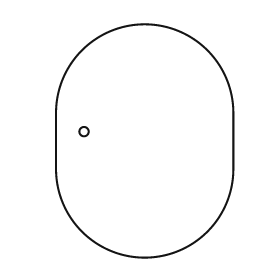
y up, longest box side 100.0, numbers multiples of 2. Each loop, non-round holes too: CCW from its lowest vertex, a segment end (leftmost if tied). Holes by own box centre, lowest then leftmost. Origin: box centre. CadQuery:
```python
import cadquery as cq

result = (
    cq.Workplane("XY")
    .moveTo(-38.0, -12.0)
    .threePointArc((0.0, -50.0), (38.0, -12.0))
    .lineTo(38.0, 12.0)
    .threePointArc((0.0, 50.0), (-38.0, 12.0))
    .close()
    .moveTo(-26.0, 4.0)
    .circle(2.0)
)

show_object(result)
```